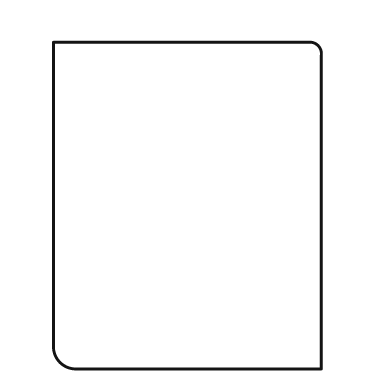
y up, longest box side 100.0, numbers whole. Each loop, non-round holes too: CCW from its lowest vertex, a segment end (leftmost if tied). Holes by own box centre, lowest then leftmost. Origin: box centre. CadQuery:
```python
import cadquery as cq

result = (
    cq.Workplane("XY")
    .moveTo(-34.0, -50.0)
    .lineTo(41.0, -50.0)
    .lineTo(41.0, 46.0)
    .threePointArc((40.0, 49.0), (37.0, 50.0))
    .lineTo(-41.0, 50.0)
    .lineTo(-41.0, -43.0)
    .threePointArc((-39.0, -48.0), (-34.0, -50.0))
    .close()
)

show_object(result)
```